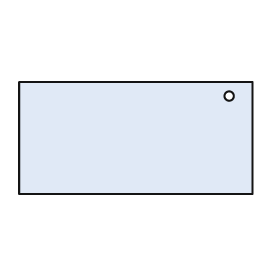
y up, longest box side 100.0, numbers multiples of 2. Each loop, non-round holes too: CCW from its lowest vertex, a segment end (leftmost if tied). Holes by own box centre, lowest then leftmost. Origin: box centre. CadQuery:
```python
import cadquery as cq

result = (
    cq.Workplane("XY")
    .moveTo(-50.0, -24.0)
    .lineTo(50.0, -24.0)
    .lineTo(50.0, 24.0)
    .lineTo(-50.0, 24.0)
    .close()
    .moveTo(40.0, 18.0)
    .circle(2.0)
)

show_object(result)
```